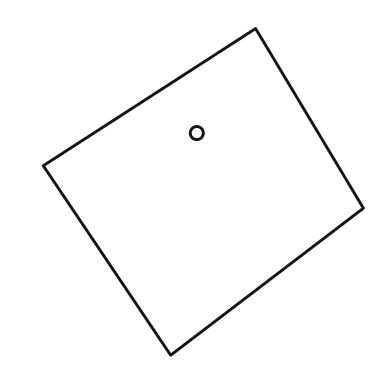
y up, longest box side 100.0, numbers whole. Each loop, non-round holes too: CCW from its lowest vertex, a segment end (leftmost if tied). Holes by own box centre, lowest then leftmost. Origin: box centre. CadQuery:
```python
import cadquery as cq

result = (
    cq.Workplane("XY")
    .moveTo(-10.0, -50.0)
    .lineTo(49.0, -5.0)
    .lineTo(16.0, 50.0)
    .lineTo(-49.0, 8.0)
    .close()
    .moveTo(-2.0, 18.0)
    .circle(2.0)
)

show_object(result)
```